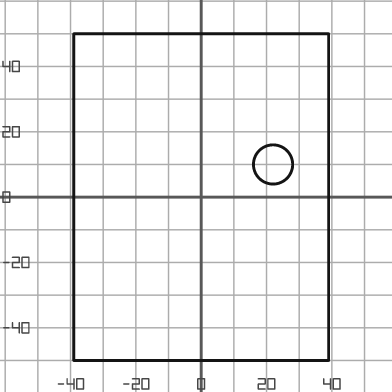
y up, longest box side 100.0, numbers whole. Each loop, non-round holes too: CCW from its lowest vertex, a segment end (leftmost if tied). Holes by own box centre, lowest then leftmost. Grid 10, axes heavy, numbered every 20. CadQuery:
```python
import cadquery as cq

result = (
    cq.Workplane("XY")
    .moveTo(-39.0, -50.0)
    .lineTo(39.0, -50.0)
    .lineTo(39.0, 50.0)
    .lineTo(-39.0, 50.0)
    .close()
    .moveTo(22.0, 10.0)
    .circle(6.0)
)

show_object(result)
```